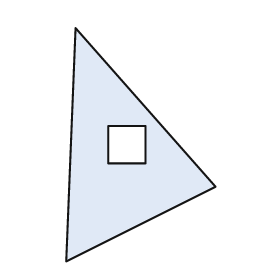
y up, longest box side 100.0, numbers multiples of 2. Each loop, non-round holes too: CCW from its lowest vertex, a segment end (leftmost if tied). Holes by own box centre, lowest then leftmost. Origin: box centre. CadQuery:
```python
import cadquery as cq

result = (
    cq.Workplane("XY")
    .moveTo(-32.0, -50.0)
    .lineTo(32.0, -18.0)
    .lineTo(-28.0, 50.0)
    .close()
    .moveTo(-14.0, -8.0)
    .lineTo(2.0, -8.0)
    .lineTo(2.0, 8.0)
    .lineTo(-14.0, 8.0)
    .close()
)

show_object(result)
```